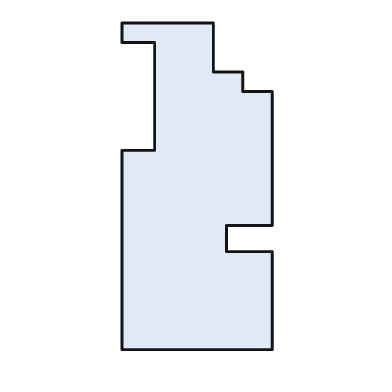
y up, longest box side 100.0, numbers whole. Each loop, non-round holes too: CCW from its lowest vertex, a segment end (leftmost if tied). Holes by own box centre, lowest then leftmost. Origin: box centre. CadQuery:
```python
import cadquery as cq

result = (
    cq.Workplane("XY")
    .moveTo(-23.0, -50.0)
    .lineTo(23.0, -50.0)
    .lineTo(23.0, -20.0)
    .lineTo(9.0, -20.0)
    .lineTo(9.0, -12.0)
    .lineTo(23.0, -12.0)
    .lineTo(23.0, 29.0)
    .lineTo(14.0, 29.0)
    .lineTo(14.0, 35.0)
    .lineTo(5.0, 35.0)
    .lineTo(5.0, 50.0)
    .lineTo(-23.0, 50.0)
    .lineTo(-23.0, 44.0)
    .lineTo(-13.0, 44.0)
    .lineTo(-13.0, 11.0)
    .lineTo(-23.0, 11.0)
    .close()
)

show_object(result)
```